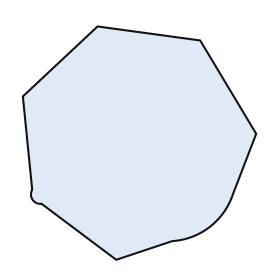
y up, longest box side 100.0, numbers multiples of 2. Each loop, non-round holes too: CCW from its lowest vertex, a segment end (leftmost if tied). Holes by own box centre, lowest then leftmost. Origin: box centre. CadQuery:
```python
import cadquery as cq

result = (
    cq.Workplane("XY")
    .moveTo(-10.0, -50.0)
    .lineTo(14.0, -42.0)
    .threePointArc((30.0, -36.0), (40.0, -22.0))
    .lineTo(50.0, 4.0)
    .lineTo(26.0, 44.0)
    .lineTo(-18.0, 50.0)
    .lineTo(-50.0, 20.0)
    .lineTo(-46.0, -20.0)
    .threePointArc((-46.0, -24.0), (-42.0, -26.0))
    .close()
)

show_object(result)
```